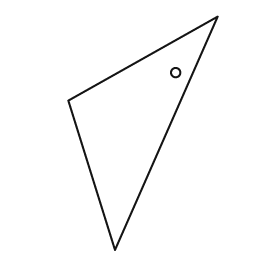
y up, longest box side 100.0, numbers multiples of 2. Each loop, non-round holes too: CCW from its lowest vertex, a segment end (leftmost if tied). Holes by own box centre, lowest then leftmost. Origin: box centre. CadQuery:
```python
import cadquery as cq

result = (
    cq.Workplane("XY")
    .moveTo(-12.0, -50.0)
    .lineTo(32.0, 50.0)
    .lineTo(-32.0, 14.0)
    .close()
    .moveTo(14.0, 26.0)
    .circle(2.0)
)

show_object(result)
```